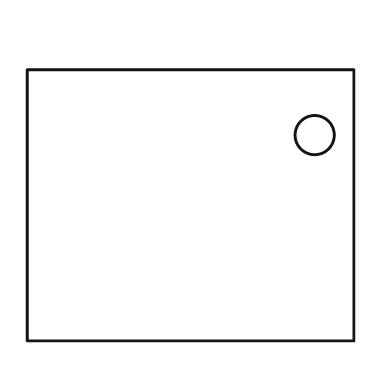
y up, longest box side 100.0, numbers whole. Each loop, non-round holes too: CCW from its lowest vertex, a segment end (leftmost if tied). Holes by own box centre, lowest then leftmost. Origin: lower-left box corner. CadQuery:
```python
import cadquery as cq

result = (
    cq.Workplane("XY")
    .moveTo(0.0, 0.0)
    .lineTo(100.0, 0.0)
    .lineTo(100.0, 83.0)
    .lineTo(0.0, 83.0)
    .close()
    .moveTo(88.0, 63.0)
    .circle(6.0)
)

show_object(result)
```